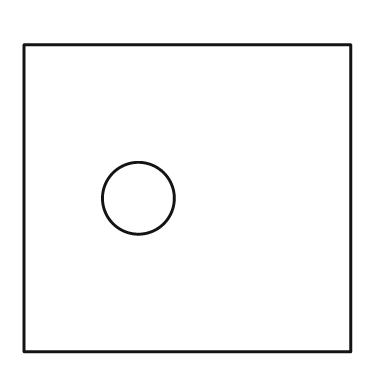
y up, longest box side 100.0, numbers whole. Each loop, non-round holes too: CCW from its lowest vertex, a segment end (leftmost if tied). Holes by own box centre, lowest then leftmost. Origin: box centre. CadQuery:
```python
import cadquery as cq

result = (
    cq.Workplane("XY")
    .moveTo(-50.0, -47.0)
    .lineTo(50.0, -47.0)
    .lineTo(50.0, 47.0)
    .lineTo(-50.0, 47.0)
    .close()
    .moveTo(-15.0, 0.0)
    .circle(11.0)
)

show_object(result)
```